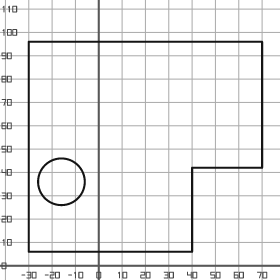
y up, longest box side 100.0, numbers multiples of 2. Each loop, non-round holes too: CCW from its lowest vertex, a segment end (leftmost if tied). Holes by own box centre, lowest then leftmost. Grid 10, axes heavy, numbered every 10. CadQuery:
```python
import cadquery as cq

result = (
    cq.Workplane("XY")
    .moveTo(-30.0, 6.0)
    .lineTo(40.0, 6.0)
    .lineTo(40.0, 42.0)
    .lineTo(70.0, 42.0)
    .lineTo(70.0, 96.0)
    .lineTo(-30.0, 96.0)
    .close()
    .moveTo(-16.0, 36.0)
    .circle(10.0)
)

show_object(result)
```